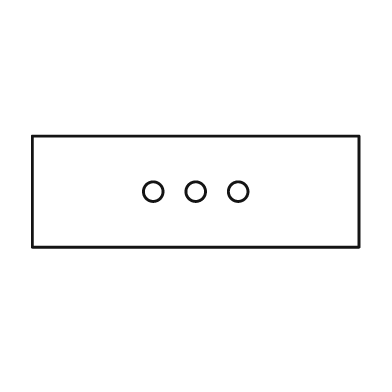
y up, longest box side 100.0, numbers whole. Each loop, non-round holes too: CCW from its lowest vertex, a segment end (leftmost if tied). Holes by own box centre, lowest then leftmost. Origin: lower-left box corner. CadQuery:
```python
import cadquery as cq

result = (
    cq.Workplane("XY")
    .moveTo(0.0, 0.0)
    .lineTo(100.0, 0.0)
    .lineTo(100.0, 34.0)
    .lineTo(0.0, 34.0)
    .close()
    .moveTo(37.0, 17.0)
    .circle(3.0)
    .moveTo(50.0, 17.0)
    .circle(3.0)
    .moveTo(63.0, 17.0)
    .circle(3.0)
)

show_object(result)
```